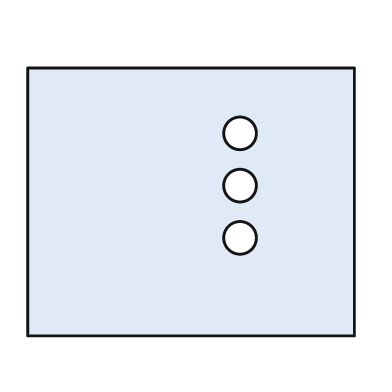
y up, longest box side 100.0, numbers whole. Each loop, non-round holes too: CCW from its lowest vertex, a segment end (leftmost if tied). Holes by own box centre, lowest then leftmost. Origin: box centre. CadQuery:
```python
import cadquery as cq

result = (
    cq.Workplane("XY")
    .moveTo(-50.0, -41.0)
    .lineTo(50.0, -41.0)
    .lineTo(50.0, 41.0)
    .lineTo(-50.0, 41.0)
    .close()
    .moveTo(15.0, -11.0)
    .circle(5.0)
    .moveTo(15.0, 5.0)
    .circle(5.0)
    .moveTo(15.0, 21.0)
    .circle(5.0)
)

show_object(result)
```